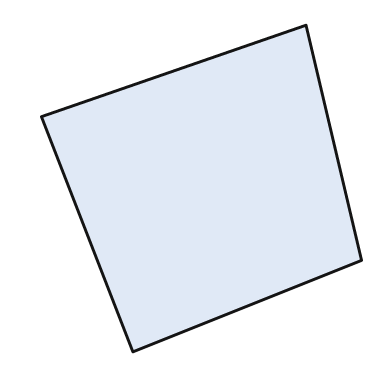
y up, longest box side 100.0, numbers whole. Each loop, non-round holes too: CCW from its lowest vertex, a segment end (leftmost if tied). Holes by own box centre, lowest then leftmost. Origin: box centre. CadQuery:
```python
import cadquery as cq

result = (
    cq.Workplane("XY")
    .moveTo(-21.0, -50.0)
    .lineTo(49.0, -22.0)
    .lineTo(32.0, 50.0)
    .lineTo(-49.0, 22.0)
    .close()
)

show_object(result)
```